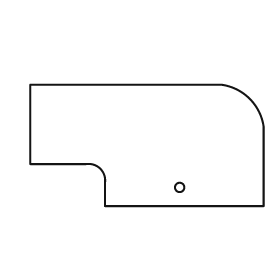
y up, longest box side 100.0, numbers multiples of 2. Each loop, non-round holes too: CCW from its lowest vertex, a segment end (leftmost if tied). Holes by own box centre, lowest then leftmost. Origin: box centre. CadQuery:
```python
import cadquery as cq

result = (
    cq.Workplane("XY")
    .moveTo(-18.0, -26.0)
    .lineTo(50.0, -26.0)
    .lineTo(50.0, 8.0)
    .threePointArc((44.0, 20.0), (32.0, 26.0))
    .lineTo(-50.0, 26.0)
    .lineTo(-50.0, -8.0)
    .lineTo(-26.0, -8.0)
    .threePointArc((-20.0, -10.0), (-18.0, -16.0))
    .close()
    .moveTo(14.0, -18.0)
    .circle(2.0)
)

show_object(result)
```